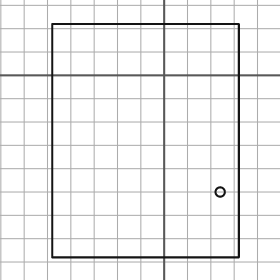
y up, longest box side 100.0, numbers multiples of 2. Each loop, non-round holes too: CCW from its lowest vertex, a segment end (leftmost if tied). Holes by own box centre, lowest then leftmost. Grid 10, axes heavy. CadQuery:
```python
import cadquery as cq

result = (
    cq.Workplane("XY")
    .moveTo(-48.0, -78.0)
    .lineTo(32.0, -78.0)
    .lineTo(32.0, 22.0)
    .lineTo(-48.0, 22.0)
    .close()
    .moveTo(24.0, -50.0)
    .circle(2.0)
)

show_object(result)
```